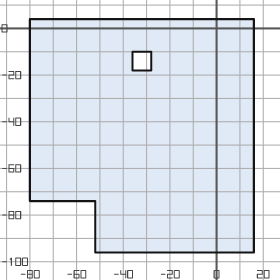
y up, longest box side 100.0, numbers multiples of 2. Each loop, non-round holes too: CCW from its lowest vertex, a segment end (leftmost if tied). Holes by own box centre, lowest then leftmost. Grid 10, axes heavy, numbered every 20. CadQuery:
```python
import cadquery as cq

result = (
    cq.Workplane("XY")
    .moveTo(-52.0, -96.0)
    .lineTo(16.0, -96.0)
    .lineTo(16.0, 4.0)
    .lineTo(-80.0, 4.0)
    .lineTo(-80.0, -74.0)
    .lineTo(-52.0, -74.0)
    .close()
    .moveTo(-36.0, -18.0)
    .lineTo(-28.0, -18.0)
    .lineTo(-28.0, -10.0)
    .lineTo(-36.0, -10.0)
    .close()
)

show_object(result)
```